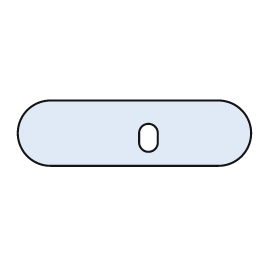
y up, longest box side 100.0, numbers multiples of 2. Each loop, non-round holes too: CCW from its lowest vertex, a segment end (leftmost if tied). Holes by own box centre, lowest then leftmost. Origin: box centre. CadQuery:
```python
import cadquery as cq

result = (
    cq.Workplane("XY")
    .moveTo(-36.0, -14.0)
    .lineTo(36.0, -14.0)
    .threePointArc((50.0, 0.0), (36.0, 14.0))
    .lineTo(-36.0, 14.0)
    .threePointArc((-50.0, 0.0), (-36.0, -14.0))
    .close()
    .moveTo(2.0, -4.0)
    .threePointArc((6.0, -8.0), (10.0, -4.0))
    .lineTo(10.0, 0.0)
    .threePointArc((6.0, 4.0), (2.0, 0.0))
    .close()
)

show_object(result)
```